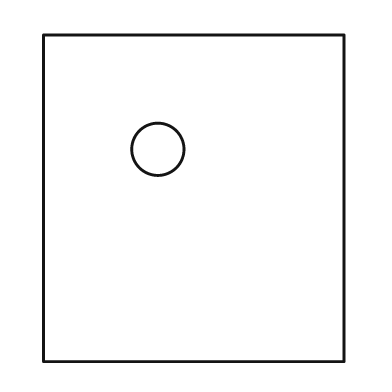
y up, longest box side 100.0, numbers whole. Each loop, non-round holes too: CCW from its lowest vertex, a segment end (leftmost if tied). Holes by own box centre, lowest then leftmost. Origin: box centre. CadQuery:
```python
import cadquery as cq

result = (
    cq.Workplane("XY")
    .moveTo(-46.0, -50.0)
    .lineTo(46.0, -50.0)
    .lineTo(46.0, 50.0)
    .lineTo(-46.0, 50.0)
    .close()
    .moveTo(-11.0, 15.0)
    .circle(8.0)
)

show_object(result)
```